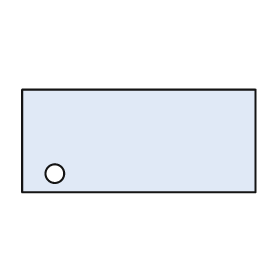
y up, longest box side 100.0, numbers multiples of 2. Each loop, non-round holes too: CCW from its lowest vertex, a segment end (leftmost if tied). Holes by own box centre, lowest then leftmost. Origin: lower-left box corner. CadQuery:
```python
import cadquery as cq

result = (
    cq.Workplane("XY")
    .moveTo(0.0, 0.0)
    .lineTo(100.0, 0.0)
    .lineTo(100.0, 44.0)
    .lineTo(0.0, 44.0)
    .close()
    .moveTo(14.0, 8.0)
    .circle(4.0)
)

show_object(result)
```